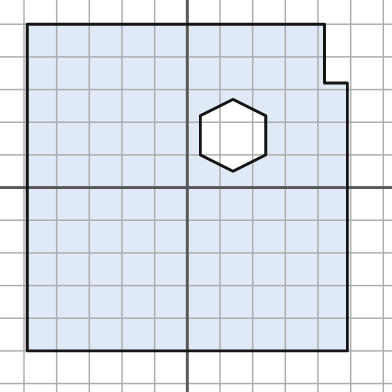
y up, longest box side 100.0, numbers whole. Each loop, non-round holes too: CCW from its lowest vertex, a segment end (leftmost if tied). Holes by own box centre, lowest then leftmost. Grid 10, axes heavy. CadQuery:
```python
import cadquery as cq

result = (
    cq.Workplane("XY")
    .moveTo(-49.0, -50.0)
    .lineTo(49.0, -50.0)
    .lineTo(49.0, 32.0)
    .lineTo(42.0, 32.0)
    .lineTo(42.0, 50.0)
    .lineTo(-49.0, 50.0)
    .close()
    .moveTo(14.0, 5.0)
    .lineTo(24.0, 10.0)
    .lineTo(24.0, 22.0)
    .lineTo(14.0, 27.0)
    .lineTo(4.0, 22.0)
    .lineTo(4.0, 10.0)
    .close()
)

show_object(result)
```